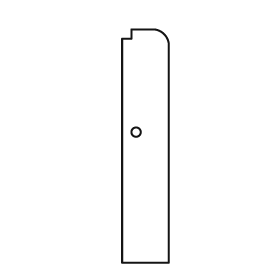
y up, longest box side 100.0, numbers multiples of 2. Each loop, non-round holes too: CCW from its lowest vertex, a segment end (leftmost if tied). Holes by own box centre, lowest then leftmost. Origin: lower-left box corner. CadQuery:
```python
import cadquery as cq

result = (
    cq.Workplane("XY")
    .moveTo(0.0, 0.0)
    .lineTo(20.0, 0.0)
    .lineTo(20.0, 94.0)
    .threePointArc((18.0, 98.0), (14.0, 100.0))
    .lineTo(4.0, 100.0)
    .lineTo(4.0, 96.0)
    .lineTo(0.0, 96.0)
    .close()
    .moveTo(6.0, 56.0)
    .circle(2.0)
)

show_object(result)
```